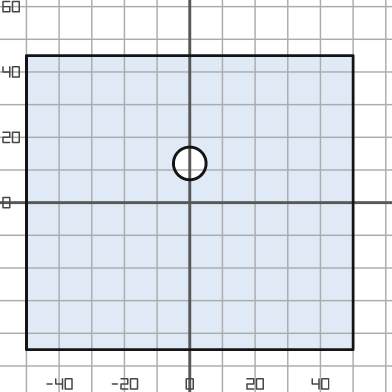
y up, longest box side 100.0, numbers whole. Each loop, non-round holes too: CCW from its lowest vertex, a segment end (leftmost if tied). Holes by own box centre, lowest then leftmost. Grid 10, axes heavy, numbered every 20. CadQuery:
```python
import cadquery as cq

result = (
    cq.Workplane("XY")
    .moveTo(-50.0, -45.0)
    .lineTo(50.0, -45.0)
    .lineTo(50.0, 45.0)
    .lineTo(-50.0, 45.0)
    .close()
    .moveTo(0.0, 12.0)
    .circle(5.0)
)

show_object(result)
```